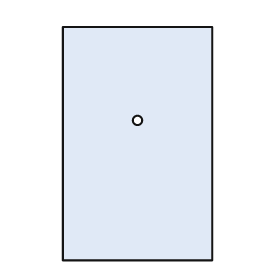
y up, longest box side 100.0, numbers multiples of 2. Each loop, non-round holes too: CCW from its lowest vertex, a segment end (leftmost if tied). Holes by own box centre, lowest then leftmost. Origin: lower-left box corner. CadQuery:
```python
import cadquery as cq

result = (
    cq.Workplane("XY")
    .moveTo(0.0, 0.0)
    .lineTo(64.0, 0.0)
    .lineTo(64.0, 100.0)
    .lineTo(0.0, 100.0)
    .close()
    .moveTo(32.0, 60.0)
    .circle(2.0)
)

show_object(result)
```